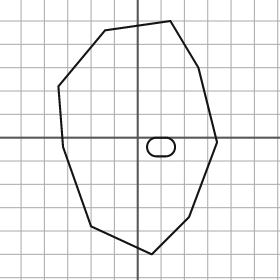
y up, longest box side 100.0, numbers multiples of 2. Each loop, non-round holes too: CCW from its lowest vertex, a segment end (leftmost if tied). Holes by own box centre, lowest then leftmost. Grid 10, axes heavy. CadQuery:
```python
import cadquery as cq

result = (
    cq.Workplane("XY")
    .moveTo(6.0, -50.0)
    .lineTo(22.0, -34.0)
    .lineTo(34.0, -2.0)
    .lineTo(26.0, 30.0)
    .lineTo(14.0, 50.0)
    .lineTo(-14.0, 46.0)
    .lineTo(-34.0, 22.0)
    .lineTo(-32.0, -4.0)
    .lineTo(-20.0, -38.0)
    .close()
    .moveTo(8.0, -8.0)
    .lineTo(12.0, -8.0)
    .threePointArc((16.0, -4.0), (12.0, 0.0))
    .lineTo(8.0, 0.0)
    .threePointArc((4.0, -4.0), (8.0, -8.0))
    .close()
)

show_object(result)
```